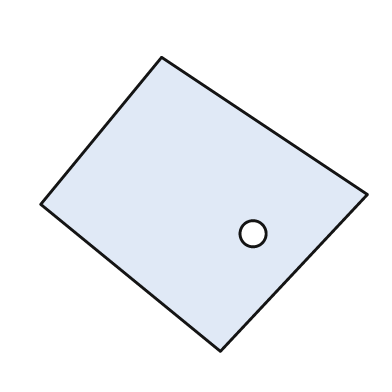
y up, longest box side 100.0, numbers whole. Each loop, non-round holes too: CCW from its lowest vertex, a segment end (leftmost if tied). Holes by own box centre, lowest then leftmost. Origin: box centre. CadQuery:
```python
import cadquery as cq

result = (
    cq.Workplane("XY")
    .moveTo(5.0, -45.0)
    .lineTo(50.0, 3.0)
    .lineTo(-13.0, 45.0)
    .lineTo(-50.0, 0.0)
    .close()
    .moveTo(15.0, -9.0)
    .circle(4.0)
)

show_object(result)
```